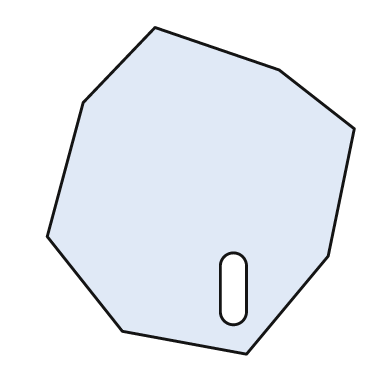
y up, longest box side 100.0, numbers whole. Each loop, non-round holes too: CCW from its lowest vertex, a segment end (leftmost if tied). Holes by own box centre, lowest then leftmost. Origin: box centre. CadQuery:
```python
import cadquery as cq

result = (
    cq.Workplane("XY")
    .moveTo(14.0, -50.0)
    .lineTo(39.0, -20.0)
    .lineTo(47.0, 19.0)
    .lineTo(24.0, 37.0)
    .lineTo(-14.0, 50.0)
    .lineTo(-36.0, 27.0)
    .lineTo(-47.0, -14.0)
    .lineTo(-24.0, -43.0)
    .close()
    .moveTo(6.0, -37.0)
    .threePointArc((10.0, -41.0), (14.0, -37.0))
    .lineTo(14.0, -23.0)
    .threePointArc((10.0, -19.0), (6.0, -23.0))
    .close()
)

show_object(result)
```